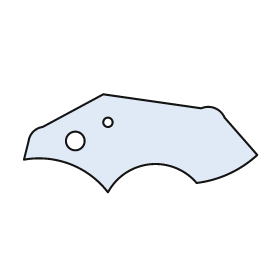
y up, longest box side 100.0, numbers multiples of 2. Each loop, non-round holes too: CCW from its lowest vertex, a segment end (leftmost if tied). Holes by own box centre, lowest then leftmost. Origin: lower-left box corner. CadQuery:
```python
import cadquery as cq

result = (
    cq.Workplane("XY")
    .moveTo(36.0, 0.0)
    .threePointArc((54.0, 12.0), (74.0, 4.0))
    .threePointArc((88.0, 8.0), (100.0, 16.0))
    .lineTo(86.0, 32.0)
    .threePointArc((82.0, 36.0), (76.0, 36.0))
    .lineTo(34.0, 42.0)
    .lineTo(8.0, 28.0)
    .threePointArc((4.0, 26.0), (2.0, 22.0))
    .lineTo(0.0, 14.0)
    .threePointArc((20.0, 12.0), (36.0, 0.0))
    .close()
    .moveTo(22.0, 22.0)
    .circle(4.0)
    .moveTo(36.0, 30.0)
    .circle(2.0)
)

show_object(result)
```